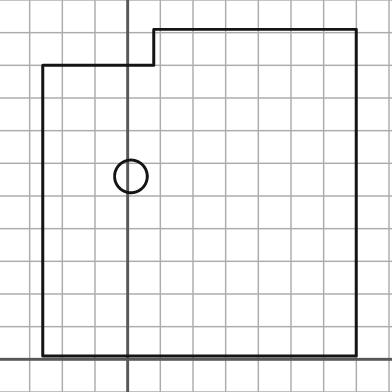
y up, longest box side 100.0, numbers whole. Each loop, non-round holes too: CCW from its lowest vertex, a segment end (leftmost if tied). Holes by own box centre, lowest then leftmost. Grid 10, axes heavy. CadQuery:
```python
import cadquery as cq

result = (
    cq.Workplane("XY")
    .moveTo(-26.0, 1.0)
    .lineTo(70.0, 1.0)
    .lineTo(70.0, 101.0)
    .lineTo(8.0, 101.0)
    .lineTo(8.0, 90.0)
    .lineTo(-26.0, 90.0)
    .close()
    .moveTo(1.0, 56.0)
    .circle(5.0)
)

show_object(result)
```